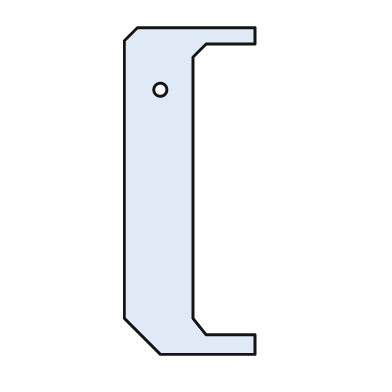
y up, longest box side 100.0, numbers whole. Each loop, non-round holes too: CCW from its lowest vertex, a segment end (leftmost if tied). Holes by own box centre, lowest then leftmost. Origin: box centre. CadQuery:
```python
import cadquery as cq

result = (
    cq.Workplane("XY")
    .moveTo(-9.0, -50.0)
    .lineTo(20.0, -50.0)
    .lineTo(20.0, -44.0)
    .lineTo(5.0, -44.0)
    .lineTo(1.0, -39.0)
    .lineTo(1.0, 41.0)
    .lineTo(5.0, 45.0)
    .lineTo(20.0, 45.0)
    .lineTo(20.0, 50.0)
    .lineTo(-16.0, 50.0)
    .lineTo(-20.0, 46.0)
    .lineTo(-20.0, -39.0)
    .close()
    .moveTo(-9.0, 31.0)
    .circle(2.0)
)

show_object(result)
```